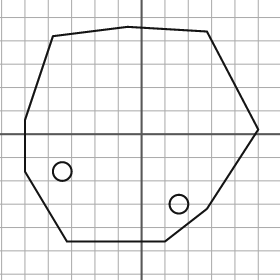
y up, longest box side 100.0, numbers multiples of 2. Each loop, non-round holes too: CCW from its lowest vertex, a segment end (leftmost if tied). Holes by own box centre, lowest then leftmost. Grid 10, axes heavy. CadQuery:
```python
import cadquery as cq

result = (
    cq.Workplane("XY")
    .moveTo(-32.0, -46.0)
    .lineTo(10.0, -46.0)
    .lineTo(28.0, -32.0)
    .lineTo(50.0, 2.0)
    .lineTo(28.0, 44.0)
    .lineTo(-6.0, 46.0)
    .lineTo(-38.0, 42.0)
    .lineTo(-50.0, 6.0)
    .lineTo(-50.0, -16.0)
    .close()
    .moveTo(16.0, -30.0)
    .circle(4.0)
    .moveTo(-34.0, -16.0)
    .circle(4.0)
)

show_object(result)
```